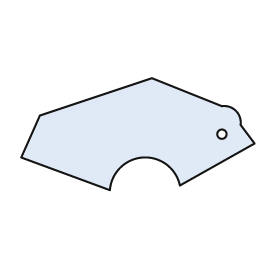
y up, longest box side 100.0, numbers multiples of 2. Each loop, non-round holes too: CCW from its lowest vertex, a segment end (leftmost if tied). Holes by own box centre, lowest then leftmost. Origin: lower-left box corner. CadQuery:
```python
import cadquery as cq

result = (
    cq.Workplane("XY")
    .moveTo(38.0, 0.0)
    .threePointArc((52.0, 14.0), (68.0, 2.0))
    .lineTo(100.0, 20.0)
    .lineTo(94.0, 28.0)
    .threePointArc((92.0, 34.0), (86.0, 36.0))
    .lineTo(56.0, 48.0)
    .lineTo(8.0, 32.0)
    .lineTo(0.0, 14.0)
    .close()
    .moveTo(86.0, 24.0)
    .circle(2.0)
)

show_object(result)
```